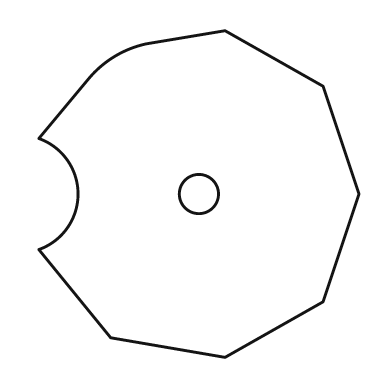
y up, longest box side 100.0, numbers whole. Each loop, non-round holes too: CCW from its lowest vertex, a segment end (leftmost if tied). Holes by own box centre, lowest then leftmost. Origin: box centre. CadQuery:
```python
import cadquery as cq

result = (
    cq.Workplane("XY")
    .moveTo(8.0, -50.0)
    .lineTo(38.0, -33.0)
    .lineTo(49.0, 0.0)
    .lineTo(38.0, 33.0)
    .lineTo(8.0, 50.0)
    .lineTo(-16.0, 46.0)
    .threePointArc((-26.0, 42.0), (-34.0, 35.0))
    .lineTo(-49.0, 17.0)
    .threePointArc((-37.0, 0.0), (-49.0, -17.0))
    .lineTo(-27.0, -44.0)
    .close()
    .moveTo(0.0, 0.0)
    .circle(6.0)
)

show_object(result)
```